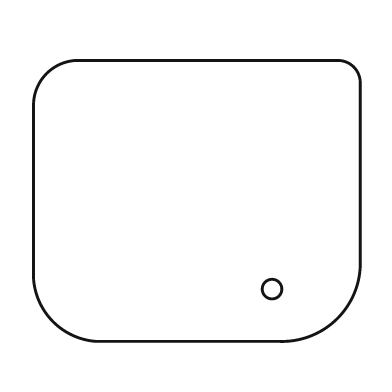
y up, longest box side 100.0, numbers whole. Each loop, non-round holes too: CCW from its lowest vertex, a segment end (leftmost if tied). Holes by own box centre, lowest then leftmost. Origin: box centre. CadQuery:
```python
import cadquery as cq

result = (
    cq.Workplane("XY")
    .moveTo(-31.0, -43.0)
    .lineTo(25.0, -43.0)
    .threePointArc((43.0, -36.0), (50.0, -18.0))
    .lineTo(50.0, 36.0)
    .threePointArc((48.0, 41.0), (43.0, 43.0))
    .lineTo(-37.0, 43.0)
    .threePointArc((-46.0, 39.0), (-50.0, 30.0))
    .lineTo(-50.0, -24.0)
    .threePointArc((-44.0, -37.0), (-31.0, -43.0))
    .close()
    .moveTo(23.0, -27.0)
    .circle(3.0)
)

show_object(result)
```